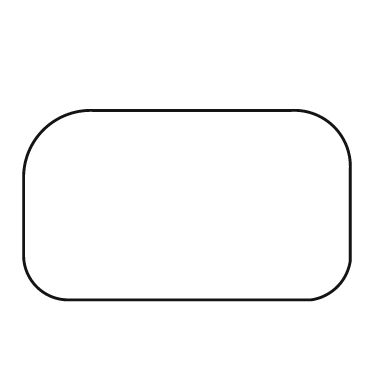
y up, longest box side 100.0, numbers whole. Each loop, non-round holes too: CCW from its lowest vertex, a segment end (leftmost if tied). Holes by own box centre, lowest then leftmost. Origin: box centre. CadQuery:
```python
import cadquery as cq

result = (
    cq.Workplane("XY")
    .moveTo(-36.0, -29.0)
    .lineTo(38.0, -29.0)
    .threePointArc((46.0, -25.0), (50.0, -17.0))
    .lineTo(50.0, 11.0)
    .threePointArc((45.0, 24.0), (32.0, 29.0))
    .lineTo(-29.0, 29.0)
    .threePointArc((-44.0, 23.0), (-50.0, 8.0))
    .lineTo(-50.0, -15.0)
    .threePointArc((-46.0, -25.0), (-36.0, -29.0))
    .close()
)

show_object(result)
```